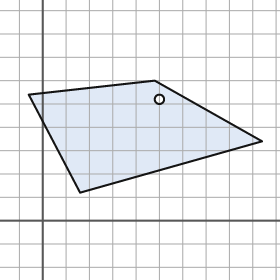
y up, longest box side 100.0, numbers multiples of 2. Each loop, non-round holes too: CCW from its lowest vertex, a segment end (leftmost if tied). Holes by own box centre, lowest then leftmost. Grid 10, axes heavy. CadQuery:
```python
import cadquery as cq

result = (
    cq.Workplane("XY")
    .moveTo(16.0, 12.0)
    .lineTo(94.0, 34.0)
    .lineTo(48.0, 60.0)
    .lineTo(-6.0, 54.0)
    .close()
    .moveTo(50.0, 52.0)
    .circle(2.0)
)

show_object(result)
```